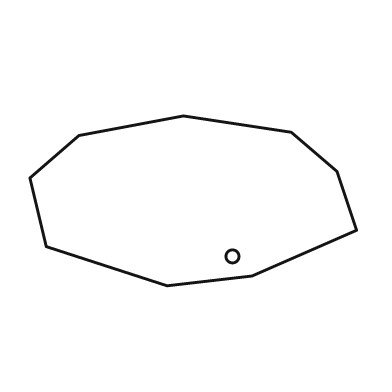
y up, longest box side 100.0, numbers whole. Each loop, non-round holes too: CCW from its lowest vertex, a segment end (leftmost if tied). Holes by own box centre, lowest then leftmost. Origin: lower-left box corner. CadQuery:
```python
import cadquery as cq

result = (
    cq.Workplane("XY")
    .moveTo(42.0, 0.0)
    .lineTo(68.0, 3.0)
    .lineTo(100.0, 17.0)
    .lineTo(94.0, 35.0)
    .lineTo(80.0, 47.0)
    .lineTo(47.0, 52.0)
    .lineTo(15.0, 46.0)
    .lineTo(0.0, 33.0)
    .lineTo(5.0, 12.0)
    .close()
    .moveTo(62.0, 9.0)
    .circle(2.0)
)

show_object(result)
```